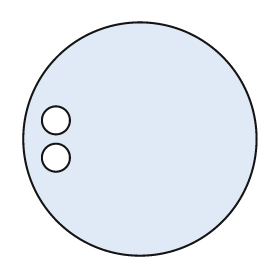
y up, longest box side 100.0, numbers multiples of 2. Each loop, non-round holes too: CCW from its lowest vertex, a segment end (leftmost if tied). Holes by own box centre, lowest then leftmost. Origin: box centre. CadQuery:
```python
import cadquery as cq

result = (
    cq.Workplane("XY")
    .moveTo(0.0, 0.0)
    .circle(50.0)
    .moveTo(-36.0, -8.0)
    .circle(6.0)
    .moveTo(-36.0, 8.0)
    .circle(6.0)
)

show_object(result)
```